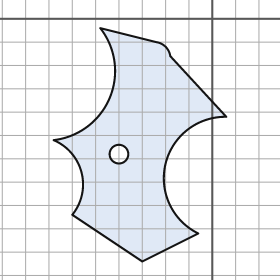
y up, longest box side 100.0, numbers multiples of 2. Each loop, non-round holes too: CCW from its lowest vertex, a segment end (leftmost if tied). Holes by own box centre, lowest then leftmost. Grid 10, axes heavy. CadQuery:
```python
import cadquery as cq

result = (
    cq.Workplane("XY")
    .moveTo(-30.0, -104.0)
    .lineTo(-6.0, -92.0)
    .threePointArc((-20.0, -62.0), (6.0, -42.0))
    .lineTo(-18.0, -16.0)
    .threePointArc((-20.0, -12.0), (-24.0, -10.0))
    .lineTo(-48.0, -4.0)
    .threePointArc((-44.0, -34.0), (-68.0, -52.0))
    .threePointArc((-56.0, -66.0), (-60.0, -84.0))
    .close()
    .moveTo(-40.0, -58.0)
    .circle(4.0)
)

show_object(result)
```